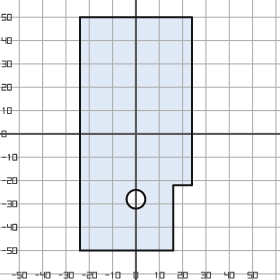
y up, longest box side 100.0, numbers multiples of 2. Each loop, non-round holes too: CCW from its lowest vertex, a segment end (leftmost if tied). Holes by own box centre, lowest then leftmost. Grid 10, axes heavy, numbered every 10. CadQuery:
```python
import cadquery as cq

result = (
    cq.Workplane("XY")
    .moveTo(-24.0, -50.0)
    .lineTo(16.0, -50.0)
    .lineTo(16.0, -22.0)
    .lineTo(24.0, -22.0)
    .lineTo(24.0, 50.0)
    .lineTo(-24.0, 50.0)
    .close()
    .moveTo(0.0, -28.0)
    .circle(4.0)
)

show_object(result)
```